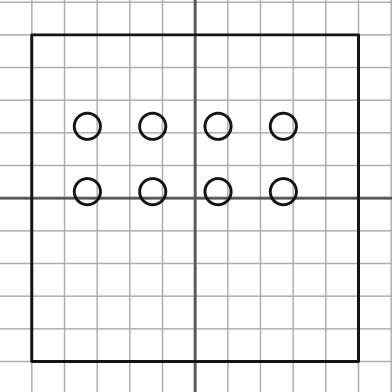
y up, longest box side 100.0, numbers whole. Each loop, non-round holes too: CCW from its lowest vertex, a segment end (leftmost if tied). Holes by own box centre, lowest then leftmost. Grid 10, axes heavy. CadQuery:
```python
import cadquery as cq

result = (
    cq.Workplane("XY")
    .moveTo(-50.0, -50.0)
    .lineTo(50.0, -50.0)
    .lineTo(50.0, 50.0)
    .lineTo(-50.0, 50.0)
    .close()
    .moveTo(-33.0, 2.0)
    .circle(4.0)
    .moveTo(-13.0, 2.0)
    .circle(4.0)
    .moveTo(7.0, 2.0)
    .circle(4.0)
    .moveTo(27.0, 2.0)
    .circle(4.0)
    .moveTo(-33.0, 22.0)
    .circle(4.0)
    .moveTo(-13.0, 22.0)
    .circle(4.0)
    .moveTo(7.0, 22.0)
    .circle(4.0)
    .moveTo(27.0, 22.0)
    .circle(4.0)
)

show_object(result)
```